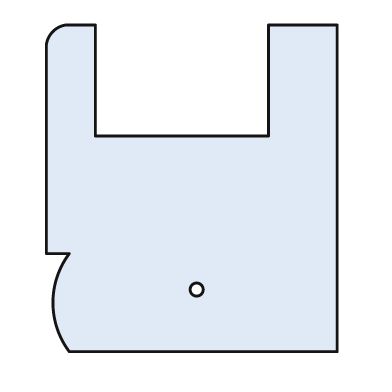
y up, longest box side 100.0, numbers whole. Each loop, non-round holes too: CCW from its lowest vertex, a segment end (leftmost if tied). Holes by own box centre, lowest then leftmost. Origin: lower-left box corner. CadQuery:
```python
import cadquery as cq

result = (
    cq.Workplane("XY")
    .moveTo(7.0, 0.0)
    .lineTo(89.0, 0.0)
    .lineTo(89.0, 100.0)
    .lineTo(68.0, 100.0)
    .lineTo(68.0, 66.0)
    .lineTo(15.0, 66.0)
    .lineTo(15.0, 100.0)
    .lineTo(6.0, 100.0)
    .threePointArc((2.0, 98.0), (0.0, 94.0))
    .lineTo(0.0, 30.0)
    .lineTo(7.0, 30.0)
    .threePointArc((2.0, 15.0), (7.0, 0.0))
    .close()
    .moveTo(46.0, 19.0)
    .circle(2.0)
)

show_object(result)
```